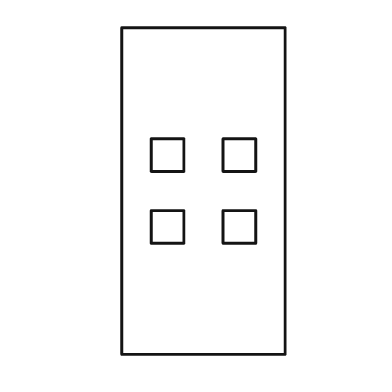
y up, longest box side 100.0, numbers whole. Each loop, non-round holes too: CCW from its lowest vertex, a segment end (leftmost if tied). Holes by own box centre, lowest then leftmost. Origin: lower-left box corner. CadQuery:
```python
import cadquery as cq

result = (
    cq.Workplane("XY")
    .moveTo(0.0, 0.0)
    .lineTo(50.0, 0.0)
    .lineTo(50.0, 100.0)
    .lineTo(0.0, 100.0)
    .close()
    .moveTo(9.0, 34.0)
    .lineTo(19.0, 34.0)
    .lineTo(19.0, 44.0)
    .lineTo(9.0, 44.0)
    .close()
    .moveTo(31.0, 34.0)
    .lineTo(41.0, 34.0)
    .lineTo(41.0, 44.0)
    .lineTo(31.0, 44.0)
    .close()
    .moveTo(9.0, 56.0)
    .lineTo(19.0, 56.0)
    .lineTo(19.0, 66.0)
    .lineTo(9.0, 66.0)
    .close()
    .moveTo(31.0, 56.0)
    .lineTo(41.0, 56.0)
    .lineTo(41.0, 66.0)
    .lineTo(31.0, 66.0)
    .close()
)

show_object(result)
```